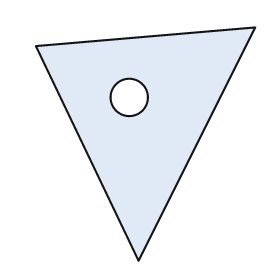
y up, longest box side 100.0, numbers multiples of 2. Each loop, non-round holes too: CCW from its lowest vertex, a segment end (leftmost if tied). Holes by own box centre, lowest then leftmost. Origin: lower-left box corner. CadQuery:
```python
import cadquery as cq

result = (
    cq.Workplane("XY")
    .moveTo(44.0, 0.0)
    .lineTo(94.0, 100.0)
    .lineTo(0.0, 92.0)
    .close()
    .moveTo(40.0, 70.0)
    .circle(8.0)
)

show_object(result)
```